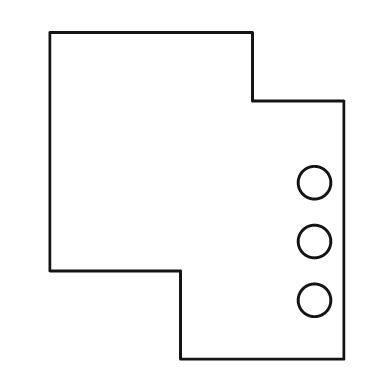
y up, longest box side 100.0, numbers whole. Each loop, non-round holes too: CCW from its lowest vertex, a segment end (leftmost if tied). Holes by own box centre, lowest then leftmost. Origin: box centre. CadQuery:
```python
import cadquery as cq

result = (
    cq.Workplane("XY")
    .moveTo(-5.0, -50.0)
    .lineTo(45.0, -50.0)
    .lineTo(45.0, 29.0)
    .lineTo(17.0, 29.0)
    .lineTo(17.0, 50.0)
    .lineTo(-45.0, 50.0)
    .lineTo(-45.0, -23.0)
    .lineTo(-5.0, -23.0)
    .close()
    .moveTo(36.0, -32.0)
    .circle(5.0)
    .moveTo(36.0, -14.0)
    .circle(5.0)
    .moveTo(36.0, 4.0)
    .circle(5.0)
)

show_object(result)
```